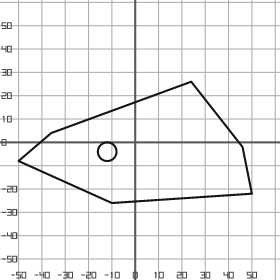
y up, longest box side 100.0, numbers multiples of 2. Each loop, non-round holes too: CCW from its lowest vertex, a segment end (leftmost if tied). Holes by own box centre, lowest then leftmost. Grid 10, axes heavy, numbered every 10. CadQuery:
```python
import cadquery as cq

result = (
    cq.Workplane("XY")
    .moveTo(-10.0, -26.0)
    .lineTo(50.0, -22.0)
    .lineTo(46.0, -2.0)
    .lineTo(24.0, 26.0)
    .lineTo(-36.0, 4.0)
    .lineTo(-50.0, -8.0)
    .close()
    .moveTo(-12.0, -4.0)
    .circle(4.0)
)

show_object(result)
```